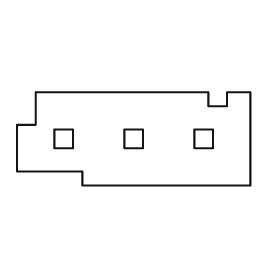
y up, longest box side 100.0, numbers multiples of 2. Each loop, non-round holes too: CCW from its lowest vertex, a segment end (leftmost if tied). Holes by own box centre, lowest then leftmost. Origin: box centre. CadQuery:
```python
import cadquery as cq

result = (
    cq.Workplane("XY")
    .moveTo(-22.0, -20.0)
    .lineTo(50.0, -20.0)
    .lineTo(50.0, 20.0)
    .lineTo(40.0, 20.0)
    .lineTo(40.0, 14.0)
    .lineTo(32.0, 14.0)
    .lineTo(32.0, 20.0)
    .lineTo(-42.0, 20.0)
    .lineTo(-42.0, 6.0)
    .lineTo(-50.0, 6.0)
    .lineTo(-50.0, -14.0)
    .lineTo(-22.0, -14.0)
    .close()
    .moveTo(-34.0, -4.0)
    .lineTo(-26.0, -4.0)
    .lineTo(-26.0, 4.0)
    .lineTo(-34.0, 4.0)
    .close()
    .moveTo(-4.0, -4.0)
    .lineTo(4.0, -4.0)
    .lineTo(4.0, 4.0)
    .lineTo(-4.0, 4.0)
    .close()
    .moveTo(26.0, -4.0)
    .lineTo(34.0, -4.0)
    .lineTo(34.0, 4.0)
    .lineTo(26.0, 4.0)
    .close()
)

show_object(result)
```